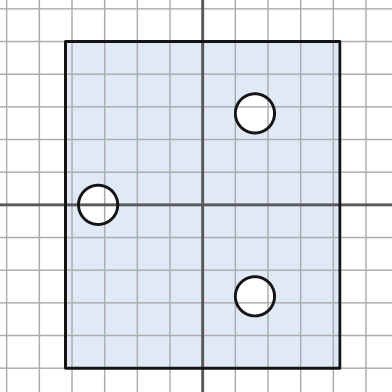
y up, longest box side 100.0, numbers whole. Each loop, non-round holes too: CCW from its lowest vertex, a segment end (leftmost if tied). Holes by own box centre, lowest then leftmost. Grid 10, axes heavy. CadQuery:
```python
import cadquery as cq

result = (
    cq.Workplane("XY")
    .moveTo(-42.0, -50.0)
    .lineTo(42.0, -50.0)
    .lineTo(42.0, 50.0)
    .lineTo(-42.0, 50.0)
    .close()
    .moveTo(16.0, -28.0)
    .circle(6.0)
    .moveTo(-32.0, 0.0)
    .circle(6.0)
    .moveTo(16.0, 28.0)
    .circle(6.0)
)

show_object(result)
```